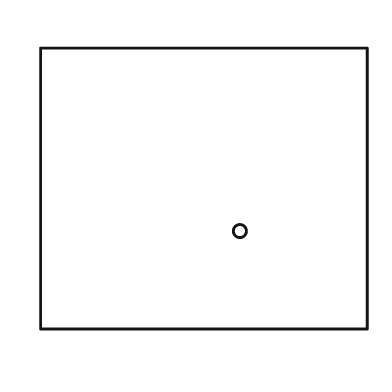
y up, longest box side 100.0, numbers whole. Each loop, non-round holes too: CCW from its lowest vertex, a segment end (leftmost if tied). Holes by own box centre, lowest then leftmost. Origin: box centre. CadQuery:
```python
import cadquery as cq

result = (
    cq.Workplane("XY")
    .moveTo(-50.0, -43.0)
    .lineTo(50.0, -43.0)
    .lineTo(50.0, 43.0)
    .lineTo(-50.0, 43.0)
    .close()
    .moveTo(11.0, -13.0)
    .circle(2.0)
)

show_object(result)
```